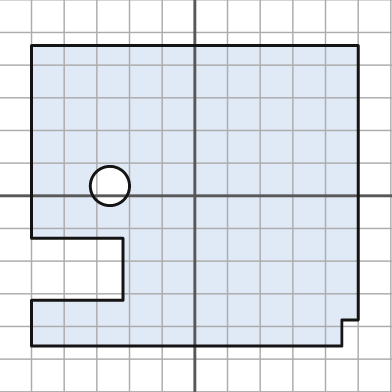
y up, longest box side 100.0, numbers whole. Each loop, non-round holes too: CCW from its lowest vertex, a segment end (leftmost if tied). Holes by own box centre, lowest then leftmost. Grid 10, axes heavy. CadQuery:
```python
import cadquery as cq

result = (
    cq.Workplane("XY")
    .moveTo(-50.0, -46.0)
    .lineTo(45.0, -46.0)
    .lineTo(45.0, -38.0)
    .lineTo(50.0, -38.0)
    .lineTo(50.0, 46.0)
    .lineTo(-50.0, 46.0)
    .lineTo(-50.0, -13.0)
    .lineTo(-22.0, -13.0)
    .lineTo(-22.0, -32.0)
    .lineTo(-50.0, -32.0)
    .close()
    .moveTo(-26.0, 3.0)
    .circle(6.0)
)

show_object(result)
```